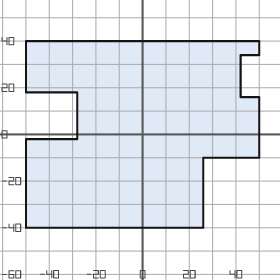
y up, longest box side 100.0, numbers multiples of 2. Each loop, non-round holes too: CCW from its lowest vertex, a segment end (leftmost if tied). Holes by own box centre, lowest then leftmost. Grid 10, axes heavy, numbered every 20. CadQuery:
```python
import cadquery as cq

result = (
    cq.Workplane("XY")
    .moveTo(-50.0, -40.0)
    .lineTo(26.0, -40.0)
    .lineTo(26.0, -10.0)
    .lineTo(50.0, -10.0)
    .lineTo(50.0, 16.0)
    .lineTo(42.0, 16.0)
    .lineTo(42.0, 34.0)
    .lineTo(50.0, 34.0)
    .lineTo(50.0, 40.0)
    .lineTo(-50.0, 40.0)
    .lineTo(-50.0, 18.0)
    .lineTo(-28.0, 18.0)
    .lineTo(-28.0, -2.0)
    .lineTo(-50.0, -2.0)
    .close()
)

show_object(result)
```